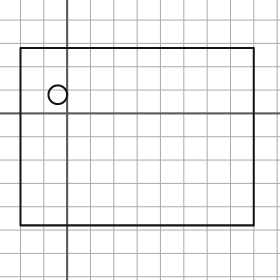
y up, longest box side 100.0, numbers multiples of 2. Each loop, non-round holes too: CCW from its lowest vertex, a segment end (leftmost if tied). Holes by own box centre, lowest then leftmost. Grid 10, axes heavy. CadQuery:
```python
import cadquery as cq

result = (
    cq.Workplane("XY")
    .moveTo(-20.0, -48.0)
    .lineTo(80.0, -48.0)
    .lineTo(80.0, 28.0)
    .lineTo(-20.0, 28.0)
    .close()
    .moveTo(-4.0, 8.0)
    .circle(4.0)
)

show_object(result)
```